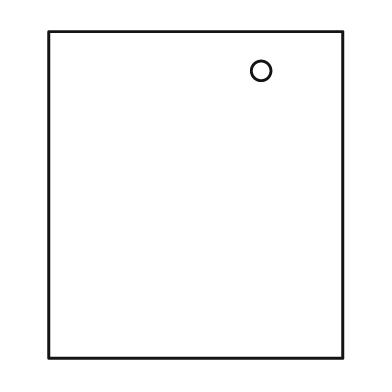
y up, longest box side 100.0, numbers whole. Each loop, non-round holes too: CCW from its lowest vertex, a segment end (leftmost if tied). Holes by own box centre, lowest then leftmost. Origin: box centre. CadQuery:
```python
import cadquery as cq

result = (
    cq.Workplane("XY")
    .moveTo(-45.0, -50.0)
    .lineTo(45.0, -50.0)
    .lineTo(45.0, 50.0)
    .lineTo(-45.0, 50.0)
    .close()
    .moveTo(20.0, 38.0)
    .circle(3.0)
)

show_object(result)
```